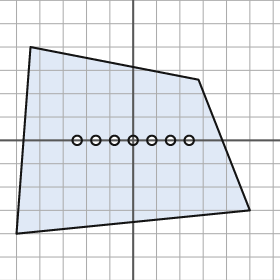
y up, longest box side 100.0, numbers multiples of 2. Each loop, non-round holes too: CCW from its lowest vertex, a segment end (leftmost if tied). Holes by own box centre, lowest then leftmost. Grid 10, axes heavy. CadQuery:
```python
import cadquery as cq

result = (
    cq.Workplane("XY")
    .moveTo(-50.0, -40.0)
    .lineTo(50.0, -30.0)
    .lineTo(28.0, 26.0)
    .lineTo(-44.0, 40.0)
    .close()
    .moveTo(-24.0, 0.0)
    .circle(2.0)
    .moveTo(-16.0, 0.0)
    .circle(2.0)
    .moveTo(-8.0, 0.0)
    .circle(2.0)
    .moveTo(0.0, 0.0)
    .circle(2.0)
    .moveTo(8.0, 0.0)
    .circle(2.0)
    .moveTo(16.0, 0.0)
    .circle(2.0)
    .moveTo(24.0, 0.0)
    .circle(2.0)
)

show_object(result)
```